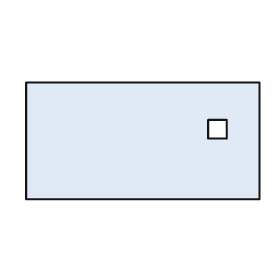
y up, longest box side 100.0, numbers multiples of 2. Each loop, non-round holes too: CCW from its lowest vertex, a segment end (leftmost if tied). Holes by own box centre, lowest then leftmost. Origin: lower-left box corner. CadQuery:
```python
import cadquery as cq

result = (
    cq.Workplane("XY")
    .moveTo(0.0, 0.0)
    .lineTo(100.0, 0.0)
    .lineTo(100.0, 50.0)
    .lineTo(0.0, 50.0)
    .close()
    .moveTo(78.0, 26.0)
    .lineTo(86.0, 26.0)
    .lineTo(86.0, 34.0)
    .lineTo(78.0, 34.0)
    .close()
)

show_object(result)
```